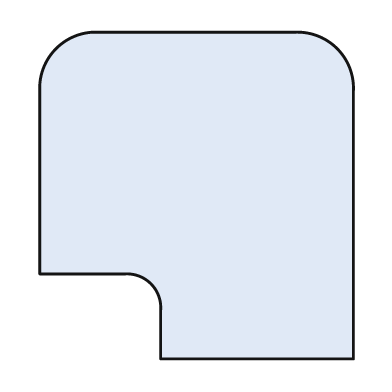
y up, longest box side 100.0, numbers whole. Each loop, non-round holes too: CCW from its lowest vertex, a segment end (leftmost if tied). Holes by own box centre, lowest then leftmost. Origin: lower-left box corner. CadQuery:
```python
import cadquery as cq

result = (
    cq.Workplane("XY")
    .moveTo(37.0, 0.0)
    .lineTo(96.0, 0.0)
    .lineTo(96.0, 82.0)
    .threePointArc((91.0, 95.0), (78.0, 100.0))
    .lineTo(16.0, 100.0)
    .threePointArc((5.0, 95.0), (0.0, 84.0))
    .lineTo(0.0, 26.0)
    .lineTo(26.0, 26.0)
    .threePointArc((34.0, 23.0), (37.0, 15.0))
    .close()
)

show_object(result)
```